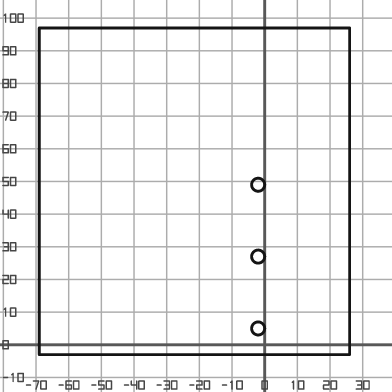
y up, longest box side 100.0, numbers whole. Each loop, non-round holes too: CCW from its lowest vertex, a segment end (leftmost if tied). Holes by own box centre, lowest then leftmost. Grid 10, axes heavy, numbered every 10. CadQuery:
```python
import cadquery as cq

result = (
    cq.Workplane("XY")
    .moveTo(-69.0, -3.0)
    .lineTo(26.0, -3.0)
    .lineTo(26.0, 97.0)
    .lineTo(-69.0, 97.0)
    .close()
    .moveTo(-2.0, 5.0)
    .circle(2.0)
    .moveTo(-2.0, 27.0)
    .circle(2.0)
    .moveTo(-2.0, 49.0)
    .circle(2.0)
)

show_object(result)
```